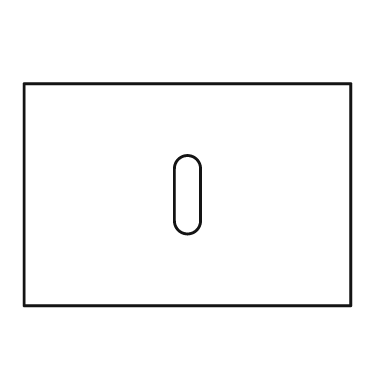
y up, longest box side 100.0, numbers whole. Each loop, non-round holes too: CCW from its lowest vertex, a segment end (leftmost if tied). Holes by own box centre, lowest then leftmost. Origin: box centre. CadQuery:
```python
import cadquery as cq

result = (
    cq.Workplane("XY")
    .moveTo(-50.0, -34.0)
    .lineTo(50.0, -34.0)
    .lineTo(50.0, 34.0)
    .lineTo(-50.0, 34.0)
    .close()
    .moveTo(-4.0, -8.0)
    .threePointArc((0.0, -12.0), (4.0, -8.0))
    .lineTo(4.0, 8.0)
    .threePointArc((0.0, 12.0), (-4.0, 8.0))
    .close()
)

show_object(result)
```